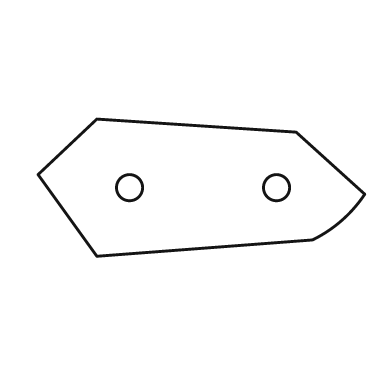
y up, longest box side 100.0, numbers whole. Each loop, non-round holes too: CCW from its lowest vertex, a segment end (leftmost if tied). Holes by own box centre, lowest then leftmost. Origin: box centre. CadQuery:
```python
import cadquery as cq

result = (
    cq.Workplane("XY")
    .moveTo(-32.0, -21.0)
    .lineTo(34.0, -16.0)
    .threePointArc((43.0, -10.0), (50.0, -2.0))
    .lineTo(29.0, 17.0)
    .lineTo(-32.0, 21.0)
    .lineTo(-50.0, 4.0)
    .close()
    .moveTo(-22.0, 0.0)
    .circle(4.0)
    .moveTo(23.0, 0.0)
    .circle(4.0)
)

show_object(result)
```